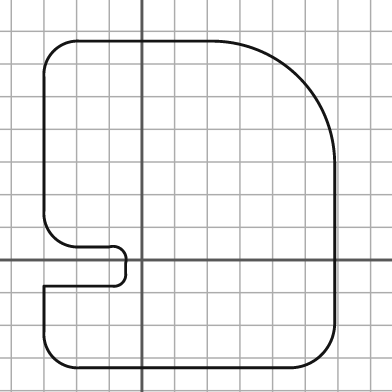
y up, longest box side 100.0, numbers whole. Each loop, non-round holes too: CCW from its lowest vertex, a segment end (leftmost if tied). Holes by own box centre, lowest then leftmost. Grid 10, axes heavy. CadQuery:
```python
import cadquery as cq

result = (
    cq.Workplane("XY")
    .moveTo(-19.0, -33.0)
    .lineTo(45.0, -33.0)
    .threePointArc((55.0, -29.0), (59.0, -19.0))
    .lineTo(59.0, 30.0)
    .threePointArc((48.0, 56.0), (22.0, 67.0))
    .lineTo(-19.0, 67.0)
    .threePointArc((-27.0, 64.0), (-30.0, 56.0))
    .lineTo(-30.0, 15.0)
    .threePointArc((-27.0, 7.0), (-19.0, 4.0))
    .lineTo(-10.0, 4.0)
    .threePointArc((-6.0, 3.0), (-5.0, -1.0))
    .lineTo(-5.0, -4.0)
    .threePointArc((-6.0, -7.0), (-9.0, -8.0))
    .lineTo(-30.0, -8.0)
    .lineTo(-30.0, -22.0)
    .threePointArc((-27.0, -30.0), (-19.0, -33.0))
    .close()
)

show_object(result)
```